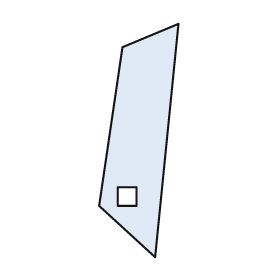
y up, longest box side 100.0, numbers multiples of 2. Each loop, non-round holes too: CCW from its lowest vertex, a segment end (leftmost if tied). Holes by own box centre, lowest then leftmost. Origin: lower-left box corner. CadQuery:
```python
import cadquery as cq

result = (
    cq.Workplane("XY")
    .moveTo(24.0, 0.0)
    .lineTo(34.0, 100.0)
    .lineTo(10.0, 90.0)
    .lineTo(0.0, 22.0)
    .close()
    .moveTo(8.0, 22.0)
    .lineTo(16.0, 22.0)
    .lineTo(16.0, 30.0)
    .lineTo(8.0, 30.0)
    .close()
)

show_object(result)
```